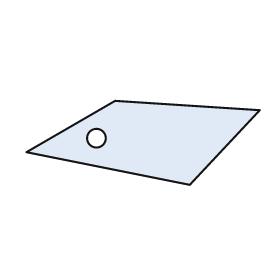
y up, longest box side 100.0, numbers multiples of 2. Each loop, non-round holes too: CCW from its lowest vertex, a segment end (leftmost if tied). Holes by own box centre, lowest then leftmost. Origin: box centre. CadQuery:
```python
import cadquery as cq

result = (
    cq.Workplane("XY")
    .moveTo(20.0, -18.0)
    .lineTo(50.0, 14.0)
    .lineTo(-12.0, 18.0)
    .lineTo(-50.0, -4.0)
    .close()
    .moveTo(-20.0, 2.0)
    .circle(4.0)
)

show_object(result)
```